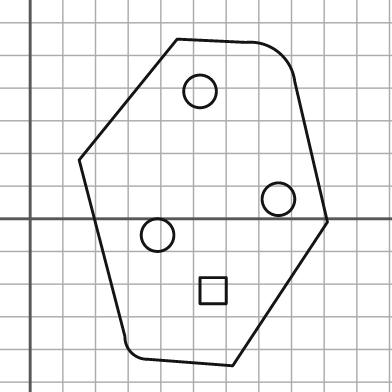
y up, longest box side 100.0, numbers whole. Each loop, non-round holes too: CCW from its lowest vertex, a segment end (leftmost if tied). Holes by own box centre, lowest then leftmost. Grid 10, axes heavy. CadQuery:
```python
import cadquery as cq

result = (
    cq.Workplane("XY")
    .moveTo(62.0, -45.0)
    .lineTo(91.0, -1.0)
    .lineTo(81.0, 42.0)
    .threePointArc((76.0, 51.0), (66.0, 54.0))
    .lineTo(45.0, 55.0)
    .lineTo(15.0, 18.0)
    .lineTo(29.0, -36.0)
    .threePointArc((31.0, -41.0), (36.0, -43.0))
    .close()
    .moveTo(52.0, -26.0)
    .lineTo(60.0, -26.0)
    .lineTo(60.0, -18.0)
    .lineTo(52.0, -18.0)
    .close()
    .moveTo(39.0, -5.0)
    .circle(5.0)
    .moveTo(76.0, 6.0)
    .circle(5.0)
    .moveTo(52.0, 39.0)
    .circle(5.0)
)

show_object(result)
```